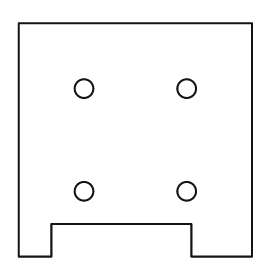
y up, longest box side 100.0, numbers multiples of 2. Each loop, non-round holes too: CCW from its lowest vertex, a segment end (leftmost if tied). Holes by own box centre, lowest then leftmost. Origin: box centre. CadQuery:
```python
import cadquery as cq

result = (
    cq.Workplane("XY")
    .moveTo(-50.0, -50.0)
    .lineTo(-36.0, -50.0)
    .lineTo(-36.0, -36.0)
    .lineTo(24.0, -36.0)
    .lineTo(24.0, -50.0)
    .lineTo(50.0, -50.0)
    .lineTo(50.0, 50.0)
    .lineTo(-50.0, 50.0)
    .close()
    .moveTo(-22.0, -22.0)
    .circle(4.0)
    .moveTo(22.0, -22.0)
    .circle(4.0)
    .moveTo(-22.0, 22.0)
    .circle(4.0)
    .moveTo(22.0, 22.0)
    .circle(4.0)
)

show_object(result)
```